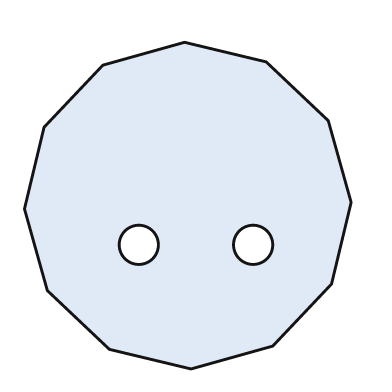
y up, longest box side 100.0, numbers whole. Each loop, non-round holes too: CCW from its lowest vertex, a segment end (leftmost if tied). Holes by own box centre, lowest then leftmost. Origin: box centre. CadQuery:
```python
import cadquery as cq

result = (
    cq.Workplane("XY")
    .moveTo(1.0, -50.0)
    .lineTo(26.0, -43.0)
    .lineTo(44.0, -24.0)
    .lineTo(50.0, 1.0)
    .lineTo(43.0, 26.0)
    .lineTo(24.0, 44.0)
    .lineTo(-1.0, 50.0)
    .lineTo(-26.0, 43.0)
    .lineTo(-44.0, 24.0)
    .lineTo(-50.0, -1.0)
    .lineTo(-43.0, -26.0)
    .lineTo(-24.0, -44.0)
    .close()
    .moveTo(-15.0, -12.0)
    .circle(6.0)
    .moveTo(20.0, -12.0)
    .circle(6.0)
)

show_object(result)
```